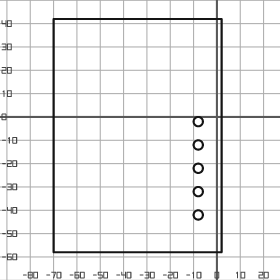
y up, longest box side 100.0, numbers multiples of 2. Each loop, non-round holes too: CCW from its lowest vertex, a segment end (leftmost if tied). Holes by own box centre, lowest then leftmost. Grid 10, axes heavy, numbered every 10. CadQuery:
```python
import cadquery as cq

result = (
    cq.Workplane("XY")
    .moveTo(-70.0, -58.0)
    .lineTo(2.0, -58.0)
    .lineTo(2.0, 42.0)
    .lineTo(-70.0, 42.0)
    .close()
    .moveTo(-8.0, -42.0)
    .circle(2.0)
    .moveTo(-8.0, -32.0)
    .circle(2.0)
    .moveTo(-8.0, -22.0)
    .circle(2.0)
    .moveTo(-8.0, -12.0)
    .circle(2.0)
    .moveTo(-8.0, -2.0)
    .circle(2.0)
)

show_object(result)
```